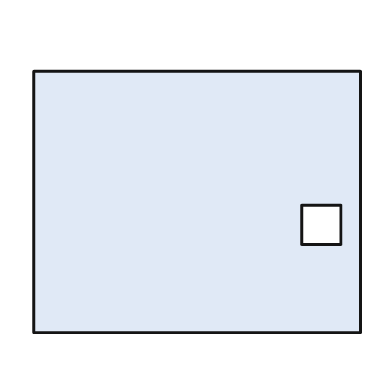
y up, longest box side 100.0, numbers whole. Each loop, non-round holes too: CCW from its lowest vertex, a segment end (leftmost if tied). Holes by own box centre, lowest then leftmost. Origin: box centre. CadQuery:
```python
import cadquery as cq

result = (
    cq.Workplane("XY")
    .moveTo(-50.0, -40.0)
    .lineTo(50.0, -40.0)
    .lineTo(50.0, 40.0)
    .lineTo(-50.0, 40.0)
    .close()
    .moveTo(32.0, -13.0)
    .lineTo(44.0, -13.0)
    .lineTo(44.0, -1.0)
    .lineTo(32.0, -1.0)
    .close()
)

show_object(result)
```